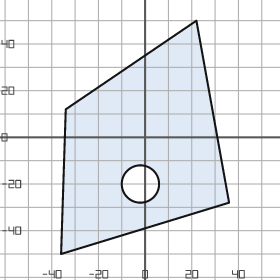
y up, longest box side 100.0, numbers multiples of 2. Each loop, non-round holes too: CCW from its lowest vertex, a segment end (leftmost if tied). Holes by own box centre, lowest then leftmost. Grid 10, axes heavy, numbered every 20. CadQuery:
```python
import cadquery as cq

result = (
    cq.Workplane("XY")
    .moveTo(-36.0, -50.0)
    .lineTo(36.0, -28.0)
    .lineTo(22.0, 50.0)
    .lineTo(-34.0, 12.0)
    .close()
    .moveTo(-2.0, -20.0)
    .circle(8.0)
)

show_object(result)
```